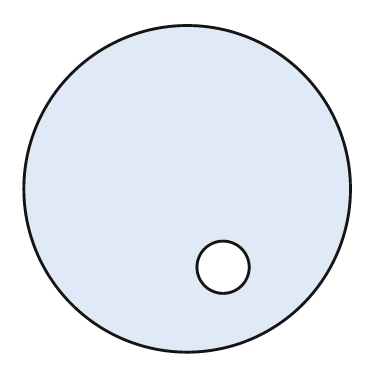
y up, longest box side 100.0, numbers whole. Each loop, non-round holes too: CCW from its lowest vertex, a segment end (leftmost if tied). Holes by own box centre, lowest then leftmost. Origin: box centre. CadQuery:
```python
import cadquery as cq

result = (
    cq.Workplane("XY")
    .moveTo(0.0, 0.0)
    .circle(50.0)
    .moveTo(11.0, -24.0)
    .circle(8.0)
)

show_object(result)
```